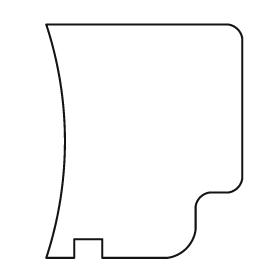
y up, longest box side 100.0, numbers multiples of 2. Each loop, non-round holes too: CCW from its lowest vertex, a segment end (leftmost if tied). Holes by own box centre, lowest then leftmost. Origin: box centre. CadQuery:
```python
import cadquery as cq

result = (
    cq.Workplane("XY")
    .moveTo(-42.0, -50.0)
    .lineTo(-30.0, -50.0)
    .lineTo(-30.0, -42.0)
    .lineTo(-18.0, -42.0)
    .lineTo(-18.0, -50.0)
    .lineTo(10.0, -50.0)
    .threePointArc((18.0, -46.0), (22.0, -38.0))
    .lineTo(22.0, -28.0)
    .threePointArc((24.0, -24.0), (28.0, -22.0))
    .lineTo(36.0, -22.0)
    .threePointArc((40.0, -20.0), (42.0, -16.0))
    .lineTo(42.0, 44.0)
    .threePointArc((40.0, 48.0), (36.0, 50.0))
    .lineTo(-42.0, 50.0)
    .threePointArc((-34.0, 0.0), (-42.0, -50.0))
    .close()
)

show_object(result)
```